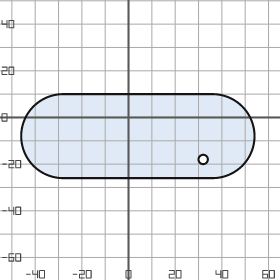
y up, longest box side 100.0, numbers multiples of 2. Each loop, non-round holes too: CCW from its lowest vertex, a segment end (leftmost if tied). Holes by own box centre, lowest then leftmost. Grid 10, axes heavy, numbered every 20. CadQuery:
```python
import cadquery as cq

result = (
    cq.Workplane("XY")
    .moveTo(-28.0, -26.0)
    .lineTo(36.0, -26.0)
    .threePointArc((54.0, -8.0), (36.0, 10.0))
    .lineTo(-28.0, 10.0)
    .threePointArc((-46.0, -8.0), (-28.0, -26.0))
    .close()
    .moveTo(32.0, -18.0)
    .circle(2.0)
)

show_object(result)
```